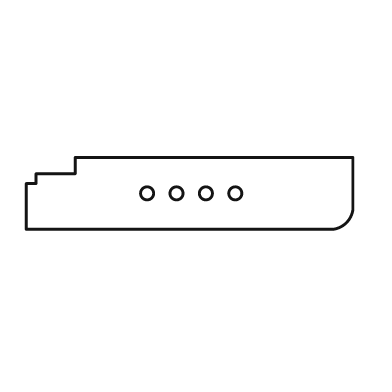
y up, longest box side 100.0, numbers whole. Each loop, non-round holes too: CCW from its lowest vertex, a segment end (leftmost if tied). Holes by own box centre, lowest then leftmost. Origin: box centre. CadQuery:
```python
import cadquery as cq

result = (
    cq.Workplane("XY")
    .moveTo(-50.0, -11.0)
    .lineTo(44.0, -11.0)
    .threePointArc((48.0, -9.0), (50.0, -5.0))
    .lineTo(50.0, 11.0)
    .lineTo(-35.0, 11.0)
    .lineTo(-35.0, 6.0)
    .lineTo(-47.0, 6.0)
    .lineTo(-47.0, 3.0)
    .lineTo(-50.0, 3.0)
    .close()
    .moveTo(-13.0, 0.0)
    .circle(2.0)
    .moveTo(-4.0, 0.0)
    .circle(2.0)
    .moveTo(5.0, 0.0)
    .circle(2.0)
    .moveTo(14.0, 0.0)
    .circle(2.0)
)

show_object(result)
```